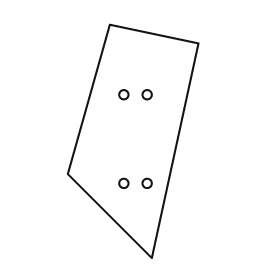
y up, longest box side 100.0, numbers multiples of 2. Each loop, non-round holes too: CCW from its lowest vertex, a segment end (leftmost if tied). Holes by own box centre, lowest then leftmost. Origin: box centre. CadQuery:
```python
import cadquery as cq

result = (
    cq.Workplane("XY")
    .moveTo(8.0, -50.0)
    .lineTo(28.0, 42.0)
    .lineTo(-10.0, 50.0)
    .lineTo(-28.0, -14.0)
    .close()
    .moveTo(-4.0, -18.0)
    .circle(2.0)
    .moveTo(6.0, -18.0)
    .circle(2.0)
    .moveTo(-4.0, 20.0)
    .circle(2.0)
    .moveTo(6.0, 20.0)
    .circle(2.0)
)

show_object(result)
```